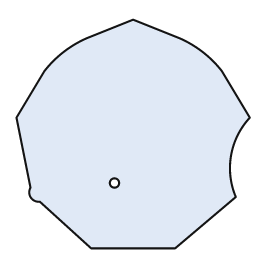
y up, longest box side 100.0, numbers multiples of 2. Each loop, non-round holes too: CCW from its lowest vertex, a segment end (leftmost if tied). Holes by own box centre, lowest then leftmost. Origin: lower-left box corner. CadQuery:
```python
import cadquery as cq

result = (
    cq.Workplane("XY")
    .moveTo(32.0, 0.0)
    .lineTo(68.0, 0.0)
    .lineTo(94.0, 22.0)
    .threePointArc((92.0, 40.0), (100.0, 56.0))
    .lineTo(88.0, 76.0)
    .threePointArc((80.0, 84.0), (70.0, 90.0))
    .lineTo(50.0, 98.0)
    .lineTo(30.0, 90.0)
    .threePointArc((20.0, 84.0), (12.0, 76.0))
    .lineTo(0.0, 56.0)
    .lineTo(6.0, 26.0)
    .threePointArc((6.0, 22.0), (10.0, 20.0))
    .close()
    .moveTo(42.0, 28.0)
    .circle(2.0)
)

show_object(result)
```